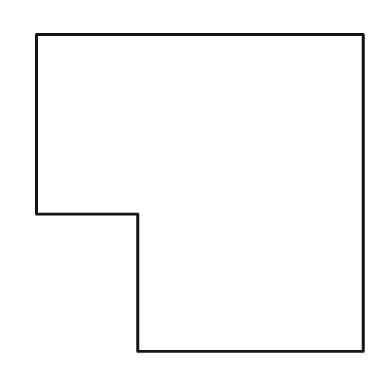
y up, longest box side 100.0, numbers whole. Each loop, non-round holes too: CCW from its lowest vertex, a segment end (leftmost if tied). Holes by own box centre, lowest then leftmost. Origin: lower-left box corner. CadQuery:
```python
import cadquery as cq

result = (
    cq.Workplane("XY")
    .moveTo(31.0, 0.0)
    .lineTo(100.0, 0.0)
    .lineTo(100.0, 97.0)
    .lineTo(0.0, 97.0)
    .lineTo(0.0, 42.0)
    .lineTo(31.0, 42.0)
    .close()
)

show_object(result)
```